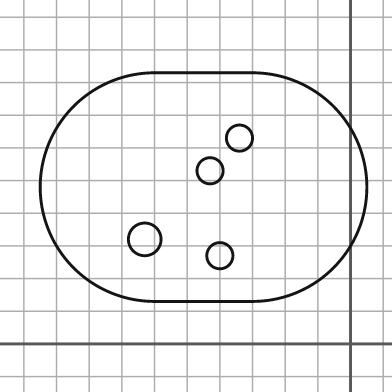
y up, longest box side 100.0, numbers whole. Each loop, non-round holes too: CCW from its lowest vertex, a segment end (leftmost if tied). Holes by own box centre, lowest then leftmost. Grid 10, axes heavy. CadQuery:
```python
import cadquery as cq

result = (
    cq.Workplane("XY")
    .moveTo(-60.0, 13.0)
    .lineTo(-30.0, 13.0)
    .threePointArc((5.0, 48.0), (-30.0, 83.0))
    .lineTo(-60.0, 83.0)
    .threePointArc((-95.0, 48.0), (-60.0, 13.0))
    .close()
    .moveTo(-40.0, 27.0)
    .circle(4.0)
    .moveTo(-63.0, 32.0)
    .circle(5.0)
    .moveTo(-43.0, 53.0)
    .circle(4.0)
    .moveTo(-34.0, 63.0)
    .circle(4.0)
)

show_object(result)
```